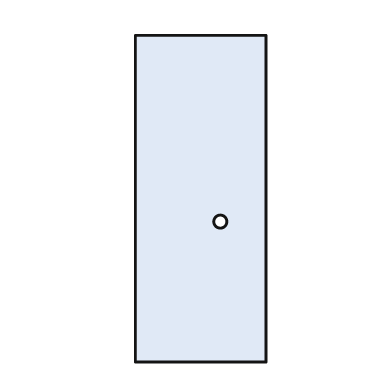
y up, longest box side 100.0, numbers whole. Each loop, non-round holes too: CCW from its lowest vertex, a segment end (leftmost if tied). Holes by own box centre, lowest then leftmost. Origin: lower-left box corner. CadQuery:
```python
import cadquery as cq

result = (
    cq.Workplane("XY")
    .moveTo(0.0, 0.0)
    .lineTo(40.0, 0.0)
    .lineTo(40.0, 100.0)
    .lineTo(0.0, 100.0)
    .close()
    .moveTo(26.0, 43.0)
    .circle(2.0)
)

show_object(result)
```